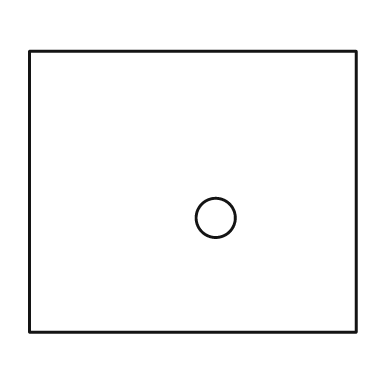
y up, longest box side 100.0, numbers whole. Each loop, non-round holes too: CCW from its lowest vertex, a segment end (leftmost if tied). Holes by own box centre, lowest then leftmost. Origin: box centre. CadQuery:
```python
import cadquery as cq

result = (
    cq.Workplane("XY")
    .moveTo(-50.0, -43.0)
    .lineTo(50.0, -43.0)
    .lineTo(50.0, 43.0)
    .lineTo(-50.0, 43.0)
    .close()
    .moveTo(7.0, -8.0)
    .circle(6.0)
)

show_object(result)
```